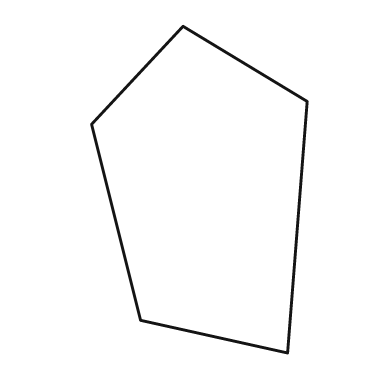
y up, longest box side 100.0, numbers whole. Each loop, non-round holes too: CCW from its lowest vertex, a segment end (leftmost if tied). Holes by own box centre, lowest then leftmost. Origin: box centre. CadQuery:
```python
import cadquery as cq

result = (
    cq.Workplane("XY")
    .moveTo(27.0, -50.0)
    .lineTo(33.0, 27.0)
    .lineTo(-5.0, 50.0)
    .lineTo(-33.0, 20.0)
    .lineTo(-18.0, -40.0)
    .close()
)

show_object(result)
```